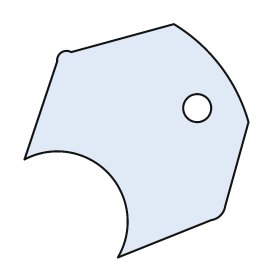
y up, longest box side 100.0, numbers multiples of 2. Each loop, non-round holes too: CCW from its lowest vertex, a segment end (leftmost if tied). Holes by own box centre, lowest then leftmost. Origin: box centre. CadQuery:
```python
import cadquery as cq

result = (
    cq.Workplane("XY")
    .moveTo(-8.0, -50.0)
    .lineTo(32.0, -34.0)
    .threePointArc((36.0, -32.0), (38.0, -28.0))
    .lineTo(48.0, 8.0)
    .threePointArc((36.0, 32.0), (16.0, 50.0))
    .lineTo(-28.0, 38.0)
    .threePointArc((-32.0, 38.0), (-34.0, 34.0))
    .lineTo(-48.0, -8.0)
    .threePointArc((-12.0, -14.0), (-8.0, -50.0))
    .close()
    .moveTo(26.0, 14.0)
    .circle(6.0)
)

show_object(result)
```